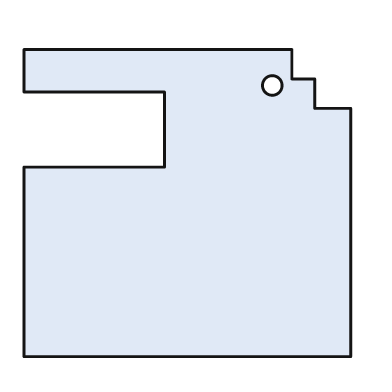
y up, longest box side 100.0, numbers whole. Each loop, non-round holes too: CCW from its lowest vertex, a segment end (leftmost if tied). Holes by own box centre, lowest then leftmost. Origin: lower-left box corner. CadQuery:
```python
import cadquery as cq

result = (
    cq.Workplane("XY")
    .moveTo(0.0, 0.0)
    .lineTo(100.0, 0.0)
    .lineTo(100.0, 76.0)
    .lineTo(89.0, 76.0)
    .lineTo(89.0, 85.0)
    .lineTo(82.0, 85.0)
    .lineTo(82.0, 94.0)
    .lineTo(0.0, 94.0)
    .lineTo(0.0, 81.0)
    .lineTo(43.0, 81.0)
    .lineTo(43.0, 58.0)
    .lineTo(0.0, 58.0)
    .close()
    .moveTo(76.0, 83.0)
    .circle(3.0)
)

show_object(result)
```